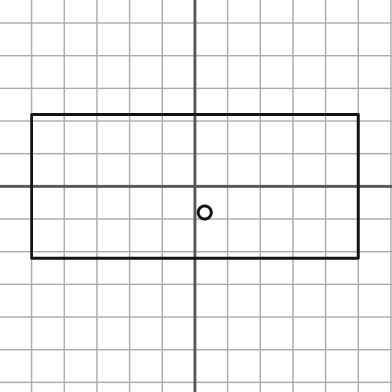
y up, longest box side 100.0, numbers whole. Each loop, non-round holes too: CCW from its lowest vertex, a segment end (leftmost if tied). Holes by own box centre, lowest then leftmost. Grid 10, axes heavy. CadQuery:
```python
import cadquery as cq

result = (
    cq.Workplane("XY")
    .moveTo(-50.0, -22.0)
    .lineTo(50.0, -22.0)
    .lineTo(50.0, 22.0)
    .lineTo(-50.0, 22.0)
    .close()
    .moveTo(3.0, -8.0)
    .circle(2.0)
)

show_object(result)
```